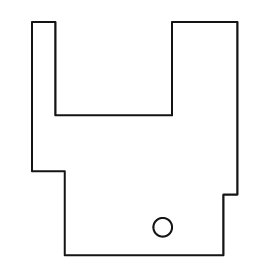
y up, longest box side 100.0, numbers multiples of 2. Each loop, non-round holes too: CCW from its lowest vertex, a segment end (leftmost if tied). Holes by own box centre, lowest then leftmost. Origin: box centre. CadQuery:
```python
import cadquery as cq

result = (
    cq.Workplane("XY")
    .moveTo(-30.0, -50.0)
    .lineTo(38.0, -50.0)
    .lineTo(38.0, -24.0)
    .lineTo(44.0, -24.0)
    .lineTo(44.0, 50.0)
    .lineTo(16.0, 50.0)
    .lineTo(16.0, 10.0)
    .lineTo(-34.0, 10.0)
    .lineTo(-34.0, 50.0)
    .lineTo(-44.0, 50.0)
    .lineTo(-44.0, -14.0)
    .lineTo(-30.0, -14.0)
    .close()
    .moveTo(12.0, -38.0)
    .circle(4.0)
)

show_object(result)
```